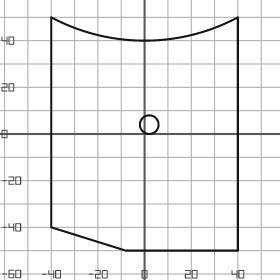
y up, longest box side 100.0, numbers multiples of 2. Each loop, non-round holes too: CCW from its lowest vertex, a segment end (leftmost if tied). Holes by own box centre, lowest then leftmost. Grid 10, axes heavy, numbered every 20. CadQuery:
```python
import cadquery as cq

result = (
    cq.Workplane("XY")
    .moveTo(-8.0, -50.0)
    .lineTo(40.0, -50.0)
    .lineTo(40.0, 50.0)
    .threePointArc((0.0, 40.0), (-40.0, 50.0))
    .lineTo(-40.0, -40.0)
    .close()
    .moveTo(2.0, 4.0)
    .circle(4.0)
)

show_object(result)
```